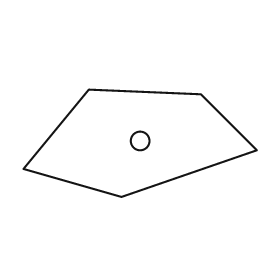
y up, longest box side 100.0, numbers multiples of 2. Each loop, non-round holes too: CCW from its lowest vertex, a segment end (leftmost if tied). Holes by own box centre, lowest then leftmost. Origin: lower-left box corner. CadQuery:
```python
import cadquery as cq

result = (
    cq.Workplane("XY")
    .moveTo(42.0, 0.0)
    .lineTo(100.0, 20.0)
    .lineTo(76.0, 44.0)
    .lineTo(28.0, 46.0)
    .lineTo(0.0, 12.0)
    .close()
    .moveTo(50.0, 24.0)
    .circle(4.0)
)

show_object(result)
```